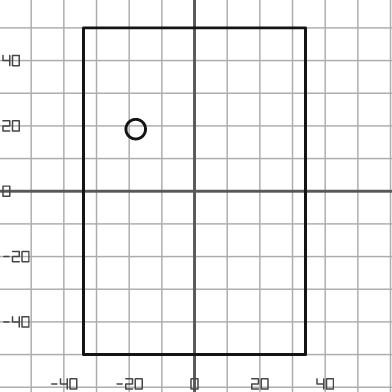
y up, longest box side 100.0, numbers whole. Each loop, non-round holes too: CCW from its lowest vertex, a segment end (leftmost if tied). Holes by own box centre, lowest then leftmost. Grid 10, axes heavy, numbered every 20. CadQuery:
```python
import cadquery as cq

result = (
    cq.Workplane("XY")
    .moveTo(-34.0, -50.0)
    .lineTo(34.0, -50.0)
    .lineTo(34.0, 50.0)
    .lineTo(-34.0, 50.0)
    .close()
    .moveTo(-18.0, 19.0)
    .circle(3.0)
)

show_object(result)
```